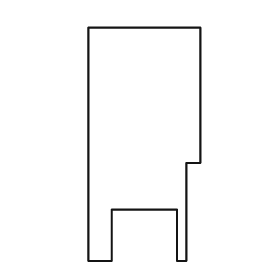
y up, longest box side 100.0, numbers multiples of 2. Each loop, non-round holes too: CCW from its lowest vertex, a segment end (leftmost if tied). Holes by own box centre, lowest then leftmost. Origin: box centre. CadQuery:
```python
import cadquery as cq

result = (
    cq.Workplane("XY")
    .moveTo(-24.0, -50.0)
    .lineTo(-14.0, -50.0)
    .lineTo(-14.0, -28.0)
    .lineTo(14.0, -28.0)
    .lineTo(14.0, -50.0)
    .lineTo(18.0, -50.0)
    .lineTo(18.0, -8.0)
    .lineTo(24.0, -8.0)
    .lineTo(24.0, 50.0)
    .lineTo(-24.0, 50.0)
    .close()
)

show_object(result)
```